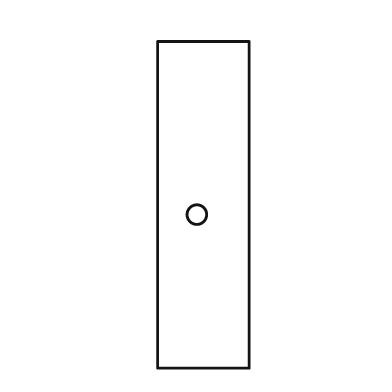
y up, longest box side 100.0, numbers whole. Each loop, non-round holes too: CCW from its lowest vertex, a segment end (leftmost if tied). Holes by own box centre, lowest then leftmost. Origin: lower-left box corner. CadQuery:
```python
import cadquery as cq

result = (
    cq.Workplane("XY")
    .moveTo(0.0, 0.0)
    .lineTo(28.0, 0.0)
    .lineTo(28.0, 100.0)
    .lineTo(0.0, 100.0)
    .close()
    .moveTo(12.0, 47.0)
    .circle(3.0)
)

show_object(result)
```